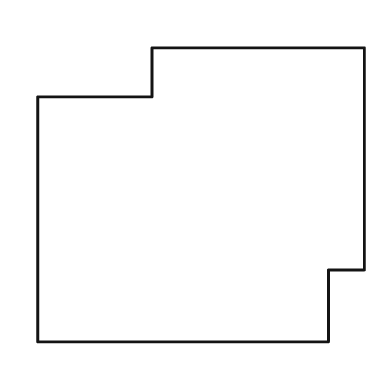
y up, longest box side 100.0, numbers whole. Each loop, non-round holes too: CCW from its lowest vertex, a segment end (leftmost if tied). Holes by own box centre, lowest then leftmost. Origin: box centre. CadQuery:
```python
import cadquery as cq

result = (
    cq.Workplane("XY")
    .moveTo(-50.0, -45.0)
    .lineTo(39.0, -45.0)
    .lineTo(39.0, -23.0)
    .lineTo(50.0, -23.0)
    .lineTo(50.0, 45.0)
    .lineTo(-15.0, 45.0)
    .lineTo(-15.0, 30.0)
    .lineTo(-50.0, 30.0)
    .close()
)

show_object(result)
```